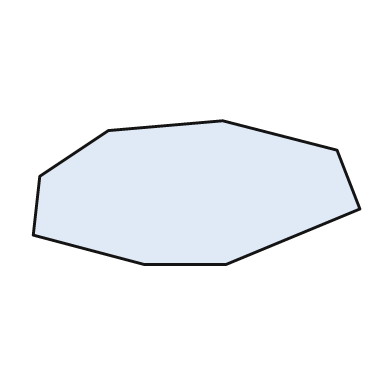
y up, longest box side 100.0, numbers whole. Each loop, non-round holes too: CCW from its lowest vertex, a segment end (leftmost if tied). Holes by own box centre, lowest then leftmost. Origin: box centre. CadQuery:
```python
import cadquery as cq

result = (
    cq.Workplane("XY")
    .moveTo(-16.0, -22.0)
    .lineTo(9.0, -22.0)
    .lineTo(50.0, -5.0)
    .lineTo(43.0, 13.0)
    .lineTo(8.0, 22.0)
    .lineTo(-27.0, 19.0)
    .lineTo(-48.0, 5.0)
    .lineTo(-50.0, -13.0)
    .close()
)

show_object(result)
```